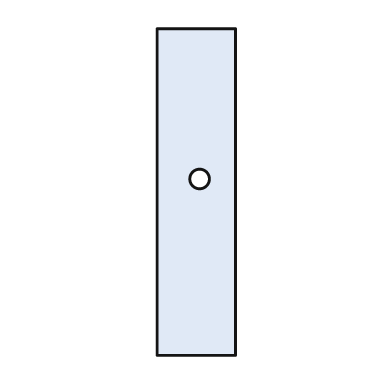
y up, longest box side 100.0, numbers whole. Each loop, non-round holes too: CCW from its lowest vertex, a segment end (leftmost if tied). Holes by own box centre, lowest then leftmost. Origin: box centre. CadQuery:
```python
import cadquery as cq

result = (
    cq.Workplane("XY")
    .moveTo(-12.0, -50.0)
    .lineTo(12.0, -50.0)
    .lineTo(12.0, 50.0)
    .lineTo(-12.0, 50.0)
    .close()
    .moveTo(1.0, 4.0)
    .circle(3.0)
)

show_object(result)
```